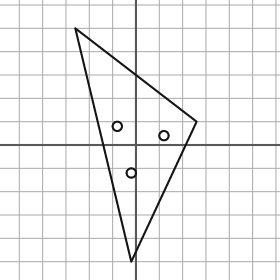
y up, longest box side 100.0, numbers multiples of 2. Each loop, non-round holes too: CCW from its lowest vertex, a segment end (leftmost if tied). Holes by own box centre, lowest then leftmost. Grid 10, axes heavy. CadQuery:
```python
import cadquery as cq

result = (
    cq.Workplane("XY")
    .moveTo(-2.0, -50.0)
    .lineTo(26.0, 10.0)
    .lineTo(-26.0, 50.0)
    .close()
    .moveTo(-2.0, -12.0)
    .circle(2.0)
    .moveTo(12.0, 4.0)
    .circle(2.0)
    .moveTo(-8.0, 8.0)
    .circle(2.0)
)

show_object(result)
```